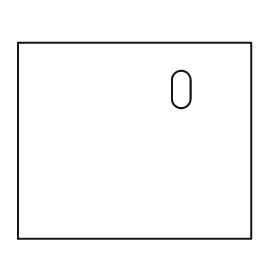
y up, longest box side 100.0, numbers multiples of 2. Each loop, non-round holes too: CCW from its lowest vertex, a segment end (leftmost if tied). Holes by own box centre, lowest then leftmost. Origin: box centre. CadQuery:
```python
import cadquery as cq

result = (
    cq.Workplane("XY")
    .moveTo(-50.0, -42.0)
    .lineTo(50.0, -42.0)
    .lineTo(50.0, 42.0)
    .lineTo(-50.0, 42.0)
    .close()
    .moveTo(16.0, 18.0)
    .threePointArc((20.0, 14.0), (24.0, 18.0))
    .lineTo(24.0, 26.0)
    .threePointArc((20.0, 30.0), (16.0, 26.0))
    .close()
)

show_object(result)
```